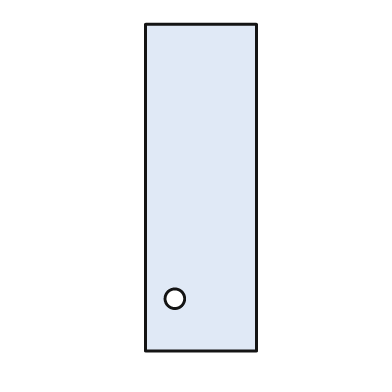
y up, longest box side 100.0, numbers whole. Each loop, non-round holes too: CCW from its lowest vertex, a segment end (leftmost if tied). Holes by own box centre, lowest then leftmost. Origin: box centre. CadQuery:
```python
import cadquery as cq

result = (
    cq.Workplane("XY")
    .moveTo(-17.0, -50.0)
    .lineTo(17.0, -50.0)
    .lineTo(17.0, 50.0)
    .lineTo(-17.0, 50.0)
    .close()
    .moveTo(-8.0, -34.0)
    .circle(3.0)
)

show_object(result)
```